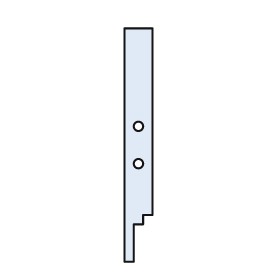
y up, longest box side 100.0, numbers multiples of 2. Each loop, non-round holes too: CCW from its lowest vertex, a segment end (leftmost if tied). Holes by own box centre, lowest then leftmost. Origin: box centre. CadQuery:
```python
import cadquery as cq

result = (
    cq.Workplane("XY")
    .moveTo(-6.0, -50.0)
    .lineTo(-2.0, -50.0)
    .lineTo(-2.0, -34.0)
    .lineTo(2.0, -34.0)
    .lineTo(2.0, -30.0)
    .lineTo(6.0, -30.0)
    .lineTo(6.0, 50.0)
    .lineTo(-6.0, 50.0)
    .close()
    .moveTo(0.0, -8.0)
    .circle(2.0)
    .moveTo(0.0, 8.0)
    .circle(2.0)
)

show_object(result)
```